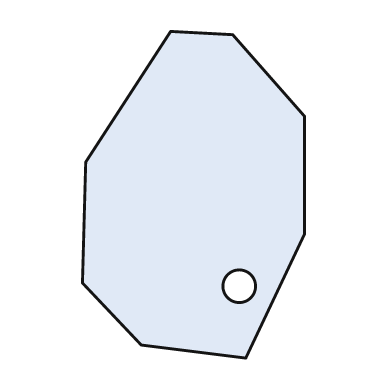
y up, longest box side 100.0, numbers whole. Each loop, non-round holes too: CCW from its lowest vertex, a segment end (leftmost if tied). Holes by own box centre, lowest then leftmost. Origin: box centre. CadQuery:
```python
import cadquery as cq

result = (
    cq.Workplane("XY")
    .moveTo(16.0, -50.0)
    .lineTo(34.0, -12.0)
    .lineTo(34.0, 24.0)
    .lineTo(12.0, 49.0)
    .lineTo(-7.0, 50.0)
    .lineTo(-33.0, 10.0)
    .lineTo(-34.0, -27.0)
    .lineTo(-16.0, -46.0)
    .close()
    .moveTo(14.0, -28.0)
    .circle(5.0)
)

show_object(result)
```